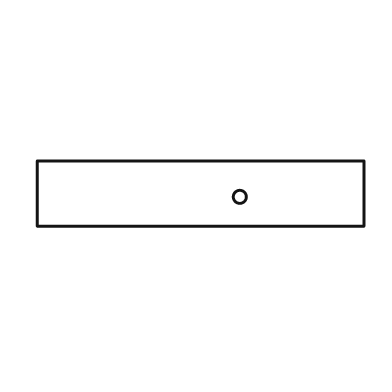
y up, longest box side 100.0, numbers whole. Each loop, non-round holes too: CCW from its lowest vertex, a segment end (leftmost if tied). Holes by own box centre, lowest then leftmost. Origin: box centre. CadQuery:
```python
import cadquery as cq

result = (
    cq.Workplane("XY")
    .moveTo(-50.0, -10.0)
    .lineTo(50.0, -10.0)
    .lineTo(50.0, 10.0)
    .lineTo(-50.0, 10.0)
    .close()
    .moveTo(12.0, -1.0)
    .circle(2.0)
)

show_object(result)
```